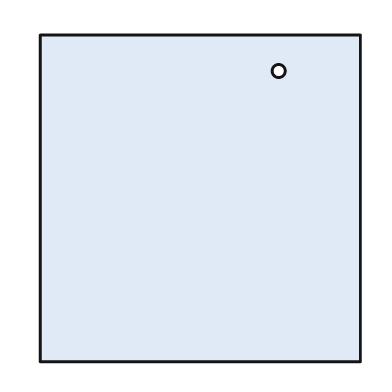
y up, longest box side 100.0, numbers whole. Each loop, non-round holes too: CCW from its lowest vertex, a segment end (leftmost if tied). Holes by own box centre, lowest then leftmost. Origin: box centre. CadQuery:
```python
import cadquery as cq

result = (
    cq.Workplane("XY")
    .moveTo(-49.0, -50.0)
    .lineTo(49.0, -50.0)
    .lineTo(49.0, 50.0)
    .lineTo(-49.0, 50.0)
    .close()
    .moveTo(24.0, 39.0)
    .circle(2.0)
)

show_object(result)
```